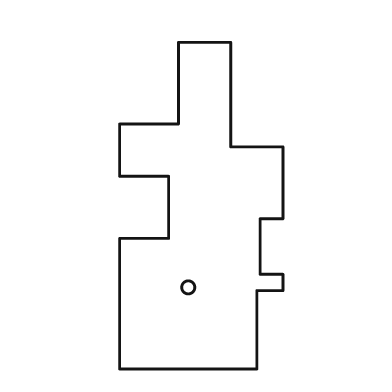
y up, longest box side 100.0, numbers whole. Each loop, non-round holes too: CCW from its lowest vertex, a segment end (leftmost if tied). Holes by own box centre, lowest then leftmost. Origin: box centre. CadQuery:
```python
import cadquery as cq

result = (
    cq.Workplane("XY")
    .moveTo(-25.0, -50.0)
    .lineTo(17.0, -50.0)
    .lineTo(17.0, -26.0)
    .lineTo(25.0, -26.0)
    .lineTo(25.0, -21.0)
    .lineTo(18.0, -21.0)
    .lineTo(18.0, -4.0)
    .lineTo(25.0, -4.0)
    .lineTo(25.0, 18.0)
    .lineTo(9.0, 18.0)
    .lineTo(9.0, 50.0)
    .lineTo(-7.0, 50.0)
    .lineTo(-7.0, 25.0)
    .lineTo(-25.0, 25.0)
    .lineTo(-25.0, 9.0)
    .lineTo(-10.0, 9.0)
    .lineTo(-10.0, -10.0)
    .lineTo(-25.0, -10.0)
    .close()
    .moveTo(-4.0, -25.0)
    .circle(2.0)
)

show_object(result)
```